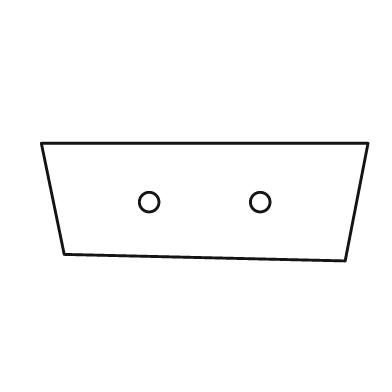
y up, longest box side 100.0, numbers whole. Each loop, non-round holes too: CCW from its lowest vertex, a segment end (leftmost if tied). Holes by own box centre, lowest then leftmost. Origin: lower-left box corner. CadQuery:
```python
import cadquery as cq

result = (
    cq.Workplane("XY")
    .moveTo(93.0, 0.0)
    .lineTo(100.0, 36.0)
    .lineTo(0.0, 36.0)
    .lineTo(7.0, 2.0)
    .close()
    .moveTo(33.0, 18.0)
    .circle(3.0)
    .moveTo(67.0, 18.0)
    .circle(3.0)
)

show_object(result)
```